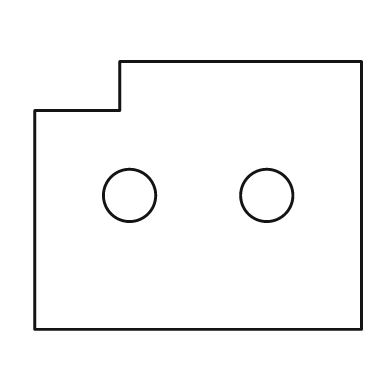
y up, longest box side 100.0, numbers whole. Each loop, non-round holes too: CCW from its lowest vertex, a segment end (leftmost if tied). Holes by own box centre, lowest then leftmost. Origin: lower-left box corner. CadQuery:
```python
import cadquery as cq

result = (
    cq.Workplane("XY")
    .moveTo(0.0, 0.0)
    .lineTo(100.0, 0.0)
    .lineTo(100.0, 82.0)
    .lineTo(26.0, 82.0)
    .lineTo(26.0, 67.0)
    .lineTo(0.0, 67.0)
    .close()
    .moveTo(29.0, 41.0)
    .circle(8.0)
    .moveTo(71.0, 41.0)
    .circle(8.0)
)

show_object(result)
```